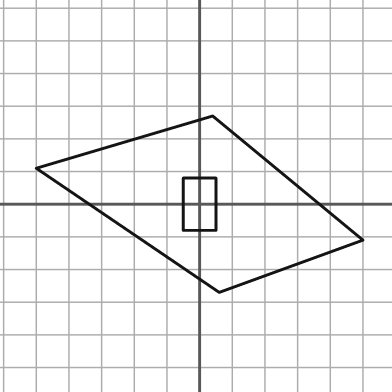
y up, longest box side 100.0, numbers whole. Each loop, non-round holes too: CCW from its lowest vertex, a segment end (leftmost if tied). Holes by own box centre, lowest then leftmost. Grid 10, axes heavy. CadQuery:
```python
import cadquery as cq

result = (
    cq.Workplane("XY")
    .moveTo(6.0, -27.0)
    .lineTo(50.0, -11.0)
    .lineTo(4.0, 27.0)
    .lineTo(-50.0, 11.0)
    .close()
    .moveTo(-5.0, -8.0)
    .lineTo(5.0, -8.0)
    .lineTo(5.0, 8.0)
    .lineTo(-5.0, 8.0)
    .close()
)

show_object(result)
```